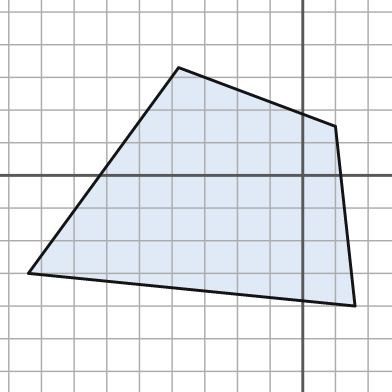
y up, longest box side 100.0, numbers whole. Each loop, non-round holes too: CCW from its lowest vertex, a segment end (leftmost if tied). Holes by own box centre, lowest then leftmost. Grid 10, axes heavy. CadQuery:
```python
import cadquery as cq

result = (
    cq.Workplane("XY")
    .moveTo(16.0, -40.0)
    .lineTo(10.0, 15.0)
    .lineTo(-38.0, 33.0)
    .lineTo(-84.0, -30.0)
    .close()
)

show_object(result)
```